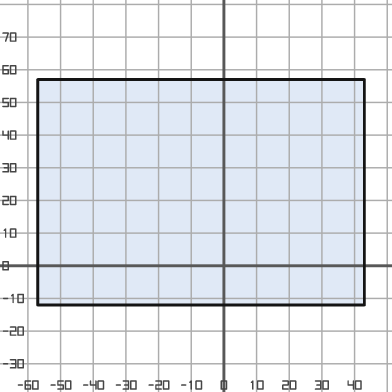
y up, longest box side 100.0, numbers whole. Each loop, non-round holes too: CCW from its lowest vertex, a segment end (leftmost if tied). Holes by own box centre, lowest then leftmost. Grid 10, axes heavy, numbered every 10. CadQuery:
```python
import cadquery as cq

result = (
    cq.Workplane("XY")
    .moveTo(-57.0, -12.0)
    .lineTo(43.0, -12.0)
    .lineTo(43.0, 57.0)
    .lineTo(-57.0, 57.0)
    .close()
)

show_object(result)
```